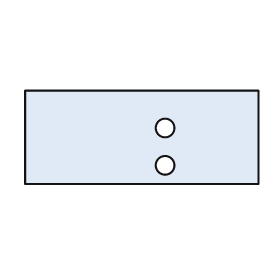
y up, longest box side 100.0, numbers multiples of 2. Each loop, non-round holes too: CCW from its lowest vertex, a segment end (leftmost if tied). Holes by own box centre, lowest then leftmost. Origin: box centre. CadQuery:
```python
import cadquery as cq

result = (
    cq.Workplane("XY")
    .moveTo(-50.0, -20.0)
    .lineTo(50.0, -20.0)
    .lineTo(50.0, 20.0)
    .lineTo(-50.0, 20.0)
    .close()
    .moveTo(10.0, -12.0)
    .circle(4.0)
    .moveTo(10.0, 4.0)
    .circle(4.0)
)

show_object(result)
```